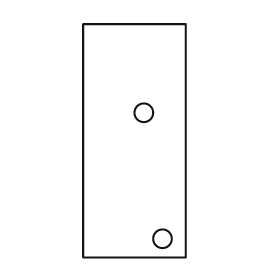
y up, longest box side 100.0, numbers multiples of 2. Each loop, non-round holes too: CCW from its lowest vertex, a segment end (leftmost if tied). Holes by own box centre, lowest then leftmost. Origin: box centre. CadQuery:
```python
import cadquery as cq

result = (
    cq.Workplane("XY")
    .moveTo(-22.0, -50.0)
    .lineTo(22.0, -50.0)
    .lineTo(22.0, 50.0)
    .lineTo(-22.0, 50.0)
    .close()
    .moveTo(12.0, -42.0)
    .circle(4.0)
    .moveTo(4.0, 12.0)
    .circle(4.0)
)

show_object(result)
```